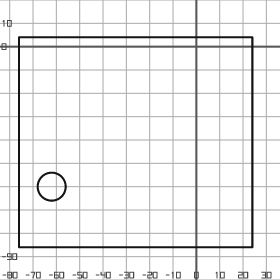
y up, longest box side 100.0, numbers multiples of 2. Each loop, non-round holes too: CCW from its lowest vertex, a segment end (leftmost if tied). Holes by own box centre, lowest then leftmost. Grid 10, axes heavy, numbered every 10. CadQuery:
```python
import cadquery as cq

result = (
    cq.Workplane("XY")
    .moveTo(-76.0, -86.0)
    .lineTo(24.0, -86.0)
    .lineTo(24.0, 4.0)
    .lineTo(-76.0, 4.0)
    .close()
    .moveTo(-62.0, -60.0)
    .circle(6.0)
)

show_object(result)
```